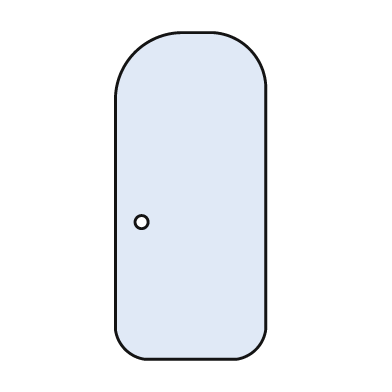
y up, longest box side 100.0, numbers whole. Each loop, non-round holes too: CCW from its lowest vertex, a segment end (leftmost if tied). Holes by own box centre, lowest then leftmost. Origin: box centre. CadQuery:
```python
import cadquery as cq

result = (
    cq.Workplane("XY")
    .moveTo(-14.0, -50.0)
    .lineTo(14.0, -50.0)
    .threePointArc((20.0, -47.0), (23.0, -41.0))
    .lineTo(23.0, 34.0)
    .threePointArc((18.0, 45.0), (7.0, 50.0))
    .lineTo(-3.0, 50.0)
    .threePointArc((-17.0, 44.0), (-23.0, 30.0))
    .lineTo(-23.0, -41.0)
    .threePointArc((-20.0, -47.0), (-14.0, -50.0))
    .close()
    .moveTo(-15.0, -8.0)
    .circle(2.0)
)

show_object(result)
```